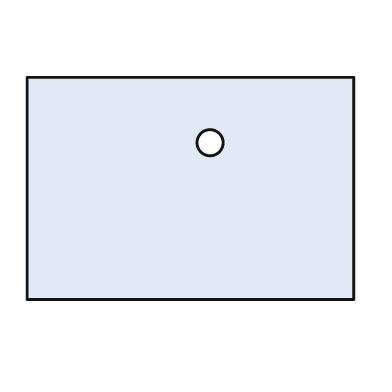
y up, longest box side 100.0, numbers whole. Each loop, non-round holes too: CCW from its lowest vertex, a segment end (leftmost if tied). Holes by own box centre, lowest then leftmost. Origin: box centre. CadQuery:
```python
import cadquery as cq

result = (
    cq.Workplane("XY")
    .moveTo(-50.0, -34.0)
    .lineTo(50.0, -34.0)
    .lineTo(50.0, 34.0)
    .lineTo(-50.0, 34.0)
    .close()
    .moveTo(6.0, 14.0)
    .circle(4.0)
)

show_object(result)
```